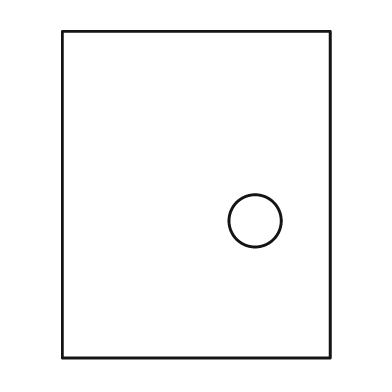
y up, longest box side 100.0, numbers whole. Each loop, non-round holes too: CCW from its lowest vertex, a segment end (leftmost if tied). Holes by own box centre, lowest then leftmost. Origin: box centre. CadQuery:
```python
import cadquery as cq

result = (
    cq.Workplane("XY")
    .moveTo(-41.0, -50.0)
    .lineTo(41.0, -50.0)
    .lineTo(41.0, 50.0)
    .lineTo(-41.0, 50.0)
    .close()
    .moveTo(18.0, -8.0)
    .circle(8.0)
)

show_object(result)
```